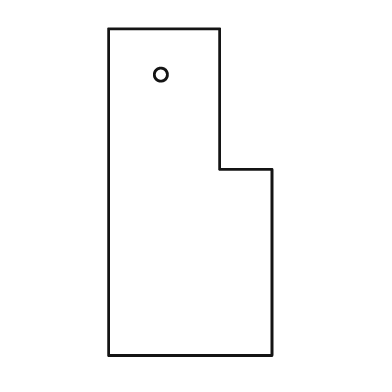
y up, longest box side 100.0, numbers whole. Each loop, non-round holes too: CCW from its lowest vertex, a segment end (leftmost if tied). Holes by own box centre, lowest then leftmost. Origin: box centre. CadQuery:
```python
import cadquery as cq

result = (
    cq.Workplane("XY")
    .moveTo(-25.0, -50.0)
    .lineTo(25.0, -50.0)
    .lineTo(25.0, 7.0)
    .lineTo(9.0, 7.0)
    .lineTo(9.0, 50.0)
    .lineTo(-25.0, 50.0)
    .close()
    .moveTo(-9.0, 36.0)
    .circle(2.0)
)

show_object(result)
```